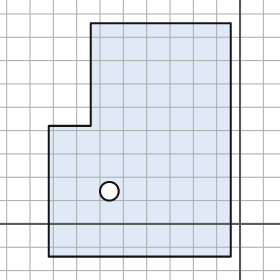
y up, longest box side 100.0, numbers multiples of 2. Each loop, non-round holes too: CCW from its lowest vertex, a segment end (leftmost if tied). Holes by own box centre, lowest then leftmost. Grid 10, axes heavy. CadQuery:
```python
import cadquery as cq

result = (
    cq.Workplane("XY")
    .moveTo(-82.0, -14.0)
    .lineTo(-4.0, -14.0)
    .lineTo(-4.0, 86.0)
    .lineTo(-64.0, 86.0)
    .lineTo(-64.0, 42.0)
    .lineTo(-82.0, 42.0)
    .close()
    .moveTo(-56.0, 14.0)
    .circle(4.0)
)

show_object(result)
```